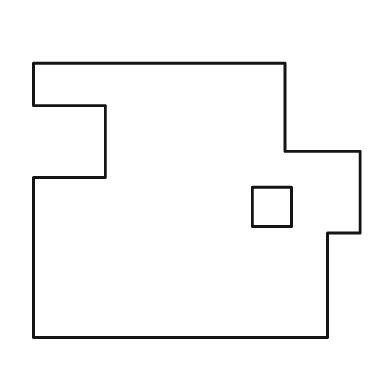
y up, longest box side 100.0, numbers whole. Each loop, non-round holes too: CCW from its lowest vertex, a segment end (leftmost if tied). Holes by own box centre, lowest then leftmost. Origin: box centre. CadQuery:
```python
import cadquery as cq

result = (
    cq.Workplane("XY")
    .moveTo(-50.0, -42.0)
    .lineTo(40.0, -42.0)
    .lineTo(40.0, -10.0)
    .lineTo(50.0, -10.0)
    .lineTo(50.0, 15.0)
    .lineTo(27.0, 15.0)
    .lineTo(27.0, 42.0)
    .lineTo(-50.0, 42.0)
    .lineTo(-50.0, 29.0)
    .lineTo(-28.0, 29.0)
    .lineTo(-28.0, 7.0)
    .lineTo(-50.0, 7.0)
    .close()
    .moveTo(17.0, -8.0)
    .lineTo(29.0, -8.0)
    .lineTo(29.0, 4.0)
    .lineTo(17.0, 4.0)
    .close()
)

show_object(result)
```